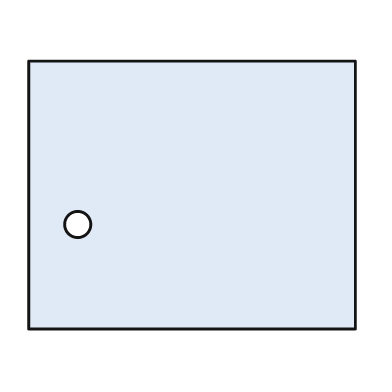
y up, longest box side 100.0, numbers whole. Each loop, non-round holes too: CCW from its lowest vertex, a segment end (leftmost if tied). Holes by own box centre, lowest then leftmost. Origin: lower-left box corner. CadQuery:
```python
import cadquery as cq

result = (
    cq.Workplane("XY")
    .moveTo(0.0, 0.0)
    .lineTo(100.0, 0.0)
    .lineTo(100.0, 82.0)
    .lineTo(0.0, 82.0)
    .close()
    .moveTo(15.0, 32.0)
    .circle(4.0)
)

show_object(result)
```